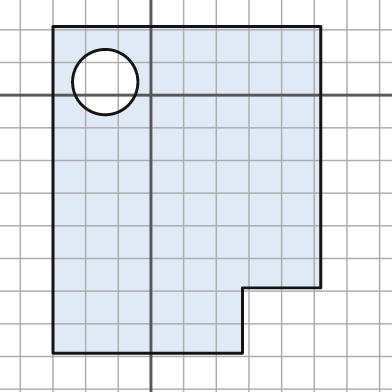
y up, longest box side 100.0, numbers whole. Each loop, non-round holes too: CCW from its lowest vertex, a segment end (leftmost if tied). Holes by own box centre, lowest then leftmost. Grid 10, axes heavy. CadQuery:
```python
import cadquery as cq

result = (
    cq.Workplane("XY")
    .moveTo(-30.0, -79.0)
    .lineTo(28.0, -79.0)
    .lineTo(28.0, -59.0)
    .lineTo(52.0, -59.0)
    .lineTo(52.0, 21.0)
    .lineTo(-30.0, 21.0)
    .close()
    .moveTo(-14.0, 4.0)
    .circle(10.0)
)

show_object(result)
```